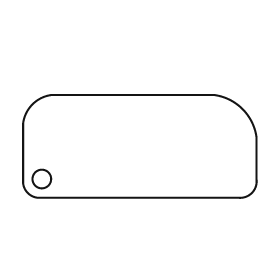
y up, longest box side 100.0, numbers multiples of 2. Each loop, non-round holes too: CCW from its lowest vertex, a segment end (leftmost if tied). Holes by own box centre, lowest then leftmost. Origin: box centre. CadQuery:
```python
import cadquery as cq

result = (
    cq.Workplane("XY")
    .moveTo(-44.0, -22.0)
    .lineTo(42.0, -22.0)
    .threePointArc((48.0, -20.0), (50.0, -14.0))
    .lineTo(50.0, 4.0)
    .threePointArc((44.0, 16.0), (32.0, 22.0))
    .lineTo(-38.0, 22.0)
    .threePointArc((-46.0, 18.0), (-50.0, 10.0))
    .lineTo(-50.0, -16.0)
    .threePointArc((-48.0, -20.0), (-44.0, -22.0))
    .close()
    .moveTo(-42.0, -14.0)
    .circle(4.0)
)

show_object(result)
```